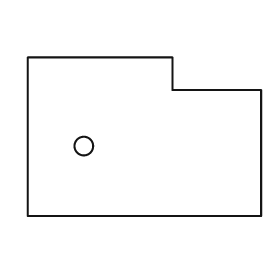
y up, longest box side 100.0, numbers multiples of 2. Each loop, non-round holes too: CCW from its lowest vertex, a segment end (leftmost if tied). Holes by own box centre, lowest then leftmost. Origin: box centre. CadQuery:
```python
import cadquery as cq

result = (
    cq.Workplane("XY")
    .moveTo(-50.0, -34.0)
    .lineTo(50.0, -34.0)
    .lineTo(50.0, 20.0)
    .lineTo(12.0, 20.0)
    .lineTo(12.0, 34.0)
    .lineTo(-50.0, 34.0)
    .close()
    .moveTo(-26.0, -4.0)
    .circle(4.0)
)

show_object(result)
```